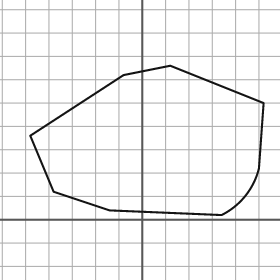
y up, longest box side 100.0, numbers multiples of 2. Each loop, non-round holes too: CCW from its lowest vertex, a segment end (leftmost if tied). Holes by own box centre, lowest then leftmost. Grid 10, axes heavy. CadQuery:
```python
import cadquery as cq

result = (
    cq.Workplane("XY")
    .moveTo(34.0, 2.0)
    .threePointArc((44.0, 10.0), (50.0, 22.0))
    .lineTo(52.0, 50.0)
    .lineTo(12.0, 66.0)
    .lineTo(-8.0, 62.0)
    .lineTo(-48.0, 36.0)
    .lineTo(-38.0, 12.0)
    .lineTo(-14.0, 4.0)
    .close()
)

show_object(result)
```